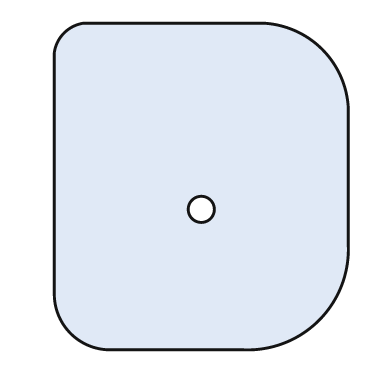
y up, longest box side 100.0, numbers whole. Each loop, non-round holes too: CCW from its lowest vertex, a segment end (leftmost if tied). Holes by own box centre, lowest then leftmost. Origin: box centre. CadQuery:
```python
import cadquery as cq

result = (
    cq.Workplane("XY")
    .moveTo(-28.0, -50.0)
    .lineTo(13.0, -50.0)
    .threePointArc((36.0, -41.0), (45.0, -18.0))
    .lineTo(45.0, 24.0)
    .threePointArc((37.0, 42.0), (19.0, 50.0))
    .lineTo(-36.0, 50.0)
    .threePointArc((-42.0, 47.0), (-45.0, 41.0))
    .lineTo(-45.0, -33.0)
    .threePointArc((-40.0, -45.0), (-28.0, -50.0))
    .close()
    .moveTo(0.0, -7.0)
    .circle(4.0)
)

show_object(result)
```